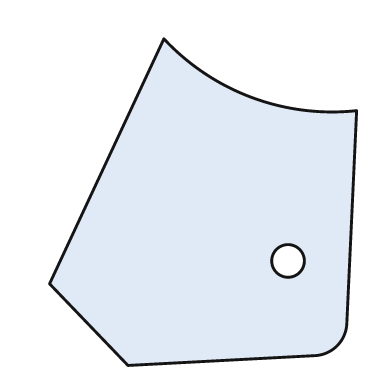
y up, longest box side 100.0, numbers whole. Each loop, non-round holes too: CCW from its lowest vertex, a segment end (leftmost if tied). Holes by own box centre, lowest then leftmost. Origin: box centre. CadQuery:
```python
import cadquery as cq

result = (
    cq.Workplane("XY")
    .moveTo(-23.0, -50.0)
    .lineTo(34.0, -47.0)
    .threePointArc((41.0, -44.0), (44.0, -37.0))
    .lineTo(47.0, 28.0)
    .threePointArc((15.0, 32.0), (-12.0, 50.0))
    .lineTo(-47.0, -25.0)
    .close()
    .moveTo(26.0, -18.0)
    .circle(5.0)
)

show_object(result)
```